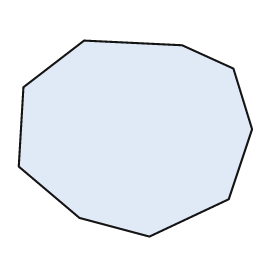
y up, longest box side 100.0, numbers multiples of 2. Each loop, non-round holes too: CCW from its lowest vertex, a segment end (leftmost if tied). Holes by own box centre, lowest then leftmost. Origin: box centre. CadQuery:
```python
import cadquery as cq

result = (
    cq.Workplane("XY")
    .moveTo(6.0, -42.0)
    .lineTo(40.0, -26.0)
    .lineTo(50.0, 4.0)
    .lineTo(42.0, 30.0)
    .lineTo(20.0, 40.0)
    .lineTo(-22.0, 42.0)
    .lineTo(-48.0, 22.0)
    .lineTo(-50.0, -12.0)
    .lineTo(-24.0, -34.0)
    .close()
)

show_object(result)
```